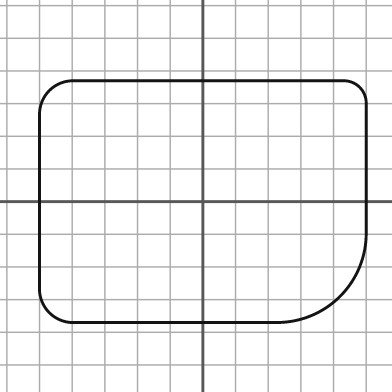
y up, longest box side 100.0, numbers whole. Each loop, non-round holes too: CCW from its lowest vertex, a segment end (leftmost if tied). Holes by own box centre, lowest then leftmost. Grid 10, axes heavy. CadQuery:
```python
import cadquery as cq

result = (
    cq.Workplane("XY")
    .moveTo(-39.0, -37.0)
    .lineTo(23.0, -37.0)
    .threePointArc((42.0, -29.0), (50.0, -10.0))
    .lineTo(50.0, 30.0)
    .threePointArc((48.0, 35.0), (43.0, 37.0))
    .lineTo(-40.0, 37.0)
    .threePointArc((-47.0, 34.0), (-50.0, 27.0))
    .lineTo(-50.0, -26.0)
    .threePointArc((-47.0, -34.0), (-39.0, -37.0))
    .close()
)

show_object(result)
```